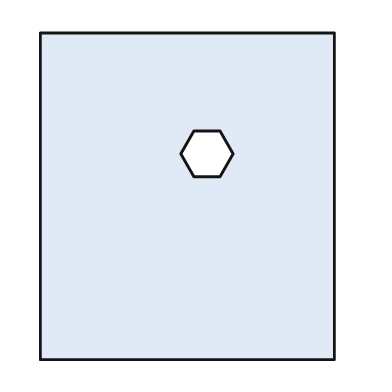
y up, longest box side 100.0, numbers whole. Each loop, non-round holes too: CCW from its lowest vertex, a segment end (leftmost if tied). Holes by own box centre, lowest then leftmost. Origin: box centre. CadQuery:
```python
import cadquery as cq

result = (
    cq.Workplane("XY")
    .moveTo(-45.0, -50.0)
    .lineTo(45.0, -50.0)
    .lineTo(45.0, 50.0)
    .lineTo(-45.0, 50.0)
    .close()
    .moveTo(2.0, 6.0)
    .lineTo(10.0, 6.0)
    .lineTo(14.0, 13.0)
    .lineTo(10.0, 20.0)
    .lineTo(2.0, 20.0)
    .lineTo(-2.0, 13.0)
    .close()
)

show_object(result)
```